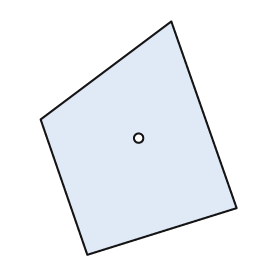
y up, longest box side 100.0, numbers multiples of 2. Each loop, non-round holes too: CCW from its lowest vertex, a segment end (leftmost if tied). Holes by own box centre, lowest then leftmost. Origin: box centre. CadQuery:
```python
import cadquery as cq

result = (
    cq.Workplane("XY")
    .moveTo(-22.0, -50.0)
    .lineTo(42.0, -30.0)
    .lineTo(14.0, 50.0)
    .lineTo(-42.0, 8.0)
    .close()
    .moveTo(0.0, 0.0)
    .circle(2.0)
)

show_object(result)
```